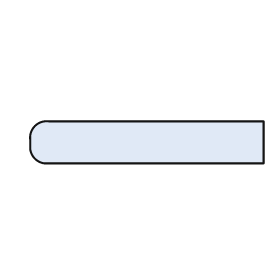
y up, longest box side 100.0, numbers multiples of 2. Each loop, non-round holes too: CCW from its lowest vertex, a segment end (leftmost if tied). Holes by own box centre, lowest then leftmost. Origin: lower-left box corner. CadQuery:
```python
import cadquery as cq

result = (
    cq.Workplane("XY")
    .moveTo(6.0, 0.0)
    .lineTo(100.0, 0.0)
    .lineTo(100.0, 18.0)
    .lineTo(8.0, 18.0)
    .threePointArc((2.0, 16.0), (0.0, 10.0))
    .lineTo(0.0, 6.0)
    .threePointArc((2.0, 2.0), (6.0, 0.0))
    .close()
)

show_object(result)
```